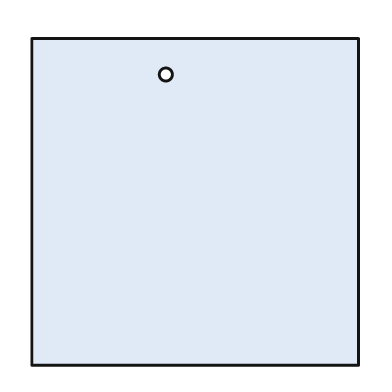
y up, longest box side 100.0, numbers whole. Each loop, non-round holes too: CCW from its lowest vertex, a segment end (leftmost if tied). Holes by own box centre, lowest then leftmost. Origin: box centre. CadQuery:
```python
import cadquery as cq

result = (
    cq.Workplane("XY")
    .moveTo(-50.0, -50.0)
    .lineTo(50.0, -50.0)
    .lineTo(50.0, 50.0)
    .lineTo(-50.0, 50.0)
    .close()
    .moveTo(-9.0, 39.0)
    .circle(2.0)
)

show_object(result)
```